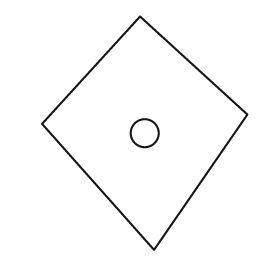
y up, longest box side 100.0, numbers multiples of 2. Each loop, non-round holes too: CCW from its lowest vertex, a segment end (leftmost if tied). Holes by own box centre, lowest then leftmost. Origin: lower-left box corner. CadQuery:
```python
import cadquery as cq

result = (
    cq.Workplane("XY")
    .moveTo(48.0, 0.0)
    .lineTo(88.0, 58.0)
    .lineTo(42.0, 100.0)
    .lineTo(0.0, 54.0)
    .close()
    .moveTo(44.0, 50.0)
    .circle(6.0)
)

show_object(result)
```